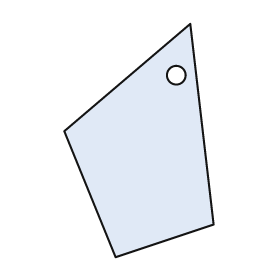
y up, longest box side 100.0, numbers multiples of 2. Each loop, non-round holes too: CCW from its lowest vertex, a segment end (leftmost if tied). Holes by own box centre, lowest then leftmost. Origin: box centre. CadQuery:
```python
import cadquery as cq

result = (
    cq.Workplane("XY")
    .moveTo(-10.0, -50.0)
    .lineTo(32.0, -36.0)
    .lineTo(22.0, 50.0)
    .lineTo(-32.0, 4.0)
    .close()
    .moveTo(16.0, 28.0)
    .circle(4.0)
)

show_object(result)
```